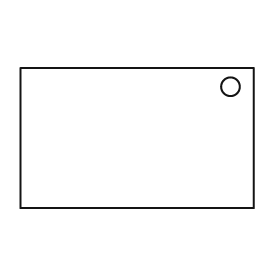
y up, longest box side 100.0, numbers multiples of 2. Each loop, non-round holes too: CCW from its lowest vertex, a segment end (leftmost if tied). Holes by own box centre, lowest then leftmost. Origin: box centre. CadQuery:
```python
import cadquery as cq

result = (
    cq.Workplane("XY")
    .moveTo(-50.0, -30.0)
    .lineTo(50.0, -30.0)
    .lineTo(50.0, 30.0)
    .lineTo(-50.0, 30.0)
    .close()
    .moveTo(40.0, 22.0)
    .circle(4.0)
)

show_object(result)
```